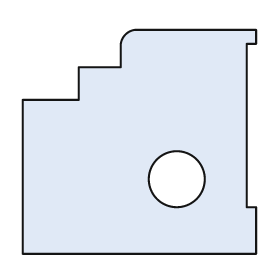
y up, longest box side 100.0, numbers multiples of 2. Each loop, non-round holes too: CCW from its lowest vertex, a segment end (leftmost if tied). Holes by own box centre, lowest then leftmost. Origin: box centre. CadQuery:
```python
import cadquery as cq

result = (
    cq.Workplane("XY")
    .moveTo(-50.0, -48.0)
    .lineTo(50.0, -48.0)
    .lineTo(50.0, -28.0)
    .lineTo(46.0, -28.0)
    .lineTo(46.0, 42.0)
    .lineTo(50.0, 42.0)
    .lineTo(50.0, 48.0)
    .lineTo(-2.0, 48.0)
    .threePointArc((-6.0, 46.0), (-8.0, 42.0))
    .lineTo(-8.0, 32.0)
    .lineTo(-26.0, 32.0)
    .lineTo(-26.0, 18.0)
    .lineTo(-50.0, 18.0)
    .close()
    .moveTo(16.0, -16.0)
    .circle(12.0)
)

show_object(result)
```